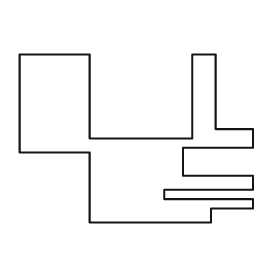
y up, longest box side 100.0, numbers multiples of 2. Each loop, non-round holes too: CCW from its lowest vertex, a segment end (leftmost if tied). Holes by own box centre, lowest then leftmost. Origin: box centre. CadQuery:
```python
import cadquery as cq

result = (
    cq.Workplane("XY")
    .moveTo(-20.0, -36.0)
    .lineTo(32.0, -36.0)
    .lineTo(32.0, -30.0)
    .lineTo(50.0, -30.0)
    .lineTo(50.0, -26.0)
    .lineTo(12.0, -26.0)
    .lineTo(12.0, -22.0)
    .lineTo(50.0, -22.0)
    .lineTo(50.0, -16.0)
    .lineTo(20.0, -16.0)
    .lineTo(20.0, -4.0)
    .lineTo(50.0, -4.0)
    .lineTo(50.0, 4.0)
    .lineTo(34.0, 4.0)
    .lineTo(34.0, 36.0)
    .lineTo(24.0, 36.0)
    .lineTo(24.0, 0.0)
    .lineTo(-20.0, 0.0)
    .lineTo(-20.0, 36.0)
    .lineTo(-50.0, 36.0)
    .lineTo(-50.0, -6.0)
    .lineTo(-20.0, -6.0)
    .close()
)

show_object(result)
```